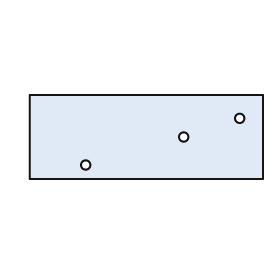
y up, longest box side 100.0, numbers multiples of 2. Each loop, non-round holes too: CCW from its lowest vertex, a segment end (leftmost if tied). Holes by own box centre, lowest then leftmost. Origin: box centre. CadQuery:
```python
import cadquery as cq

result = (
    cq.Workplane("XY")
    .moveTo(-50.0, -18.0)
    .lineTo(50.0, -18.0)
    .lineTo(50.0, 18.0)
    .lineTo(-50.0, 18.0)
    .close()
    .moveTo(-26.0, -12.0)
    .circle(2.0)
    .moveTo(16.0, 0.0)
    .circle(2.0)
    .moveTo(40.0, 8.0)
    .circle(2.0)
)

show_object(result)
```